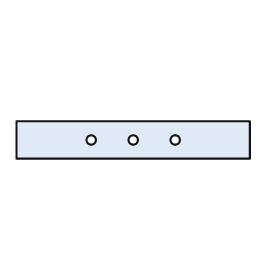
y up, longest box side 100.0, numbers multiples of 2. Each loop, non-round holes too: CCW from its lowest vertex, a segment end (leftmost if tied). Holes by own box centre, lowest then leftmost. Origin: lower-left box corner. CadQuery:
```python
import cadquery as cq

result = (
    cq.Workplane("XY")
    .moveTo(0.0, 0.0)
    .lineTo(100.0, 0.0)
    .lineTo(100.0, 16.0)
    .lineTo(0.0, 16.0)
    .close()
    .moveTo(32.0, 8.0)
    .circle(2.0)
    .moveTo(50.0, 8.0)
    .circle(2.0)
    .moveTo(68.0, 8.0)
    .circle(2.0)
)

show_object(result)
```